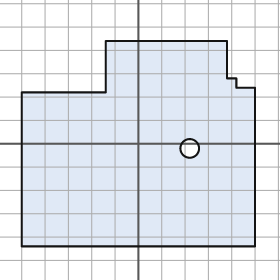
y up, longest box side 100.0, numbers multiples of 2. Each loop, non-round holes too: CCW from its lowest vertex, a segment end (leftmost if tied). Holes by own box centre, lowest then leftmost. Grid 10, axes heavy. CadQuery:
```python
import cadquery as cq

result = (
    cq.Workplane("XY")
    .moveTo(-50.0, -44.0)
    .lineTo(50.0, -44.0)
    .lineTo(50.0, 24.0)
    .lineTo(42.0, 24.0)
    .lineTo(42.0, 28.0)
    .lineTo(38.0, 28.0)
    .lineTo(38.0, 44.0)
    .lineTo(-14.0, 44.0)
    .lineTo(-14.0, 22.0)
    .lineTo(-50.0, 22.0)
    .close()
    .moveTo(22.0, -2.0)
    .circle(4.0)
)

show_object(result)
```